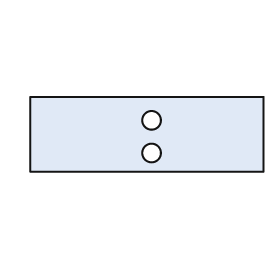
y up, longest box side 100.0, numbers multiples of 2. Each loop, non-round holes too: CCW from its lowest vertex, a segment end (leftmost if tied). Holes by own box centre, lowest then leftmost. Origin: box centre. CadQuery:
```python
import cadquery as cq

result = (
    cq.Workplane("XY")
    .moveTo(-50.0, -16.0)
    .lineTo(50.0, -16.0)
    .lineTo(50.0, 16.0)
    .lineTo(-50.0, 16.0)
    .close()
    .moveTo(2.0, -8.0)
    .circle(4.0)
    .moveTo(2.0, 6.0)
    .circle(4.0)
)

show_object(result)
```